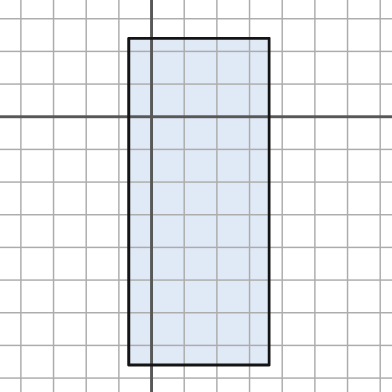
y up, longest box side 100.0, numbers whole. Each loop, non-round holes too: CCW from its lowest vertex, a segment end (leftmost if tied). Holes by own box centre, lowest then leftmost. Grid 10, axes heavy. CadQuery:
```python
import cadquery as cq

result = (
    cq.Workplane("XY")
    .moveTo(-7.0, -76.0)
    .lineTo(36.0, -76.0)
    .lineTo(36.0, 24.0)
    .lineTo(-7.0, 24.0)
    .close()
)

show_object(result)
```